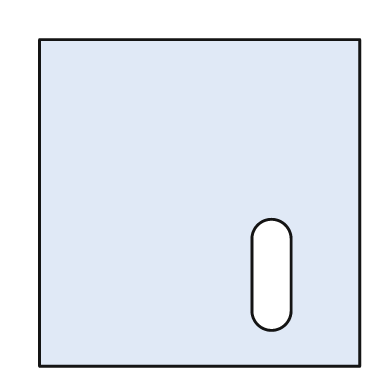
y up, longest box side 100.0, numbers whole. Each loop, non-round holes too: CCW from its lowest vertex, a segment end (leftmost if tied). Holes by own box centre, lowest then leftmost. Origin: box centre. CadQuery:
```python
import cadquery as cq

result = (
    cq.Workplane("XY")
    .moveTo(-49.0, -50.0)
    .lineTo(49.0, -50.0)
    .lineTo(49.0, 50.0)
    .lineTo(-49.0, 50.0)
    .close()
    .moveTo(16.0, -33.0)
    .threePointArc((22.0, -39.0), (28.0, -33.0))
    .lineTo(28.0, -11.0)
    .threePointArc((22.0, -5.0), (16.0, -11.0))
    .close()
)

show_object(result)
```